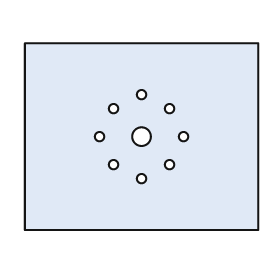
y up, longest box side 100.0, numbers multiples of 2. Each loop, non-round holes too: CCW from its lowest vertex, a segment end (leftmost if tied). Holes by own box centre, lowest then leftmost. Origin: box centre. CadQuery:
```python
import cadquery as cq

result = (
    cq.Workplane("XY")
    .moveTo(-50.0, -40.0)
    .lineTo(50.0, -40.0)
    .lineTo(50.0, 40.0)
    .lineTo(-50.0, 40.0)
    .close()
    .moveTo(0.0, -18.0)
    .circle(2.0)
    .moveTo(-12.0, -12.0)
    .circle(2.0)
    .moveTo(12.0, -12.0)
    .circle(2.0)
    .moveTo(-18.0, 0.0)
    .circle(2.0)
    .moveTo(0.0, 0.0)
    .circle(4.0)
    .moveTo(18.0, 0.0)
    .circle(2.0)
    .moveTo(-12.0, 12.0)
    .circle(2.0)
    .moveTo(12.0, 12.0)
    .circle(2.0)
    .moveTo(0.0, 18.0)
    .circle(2.0)
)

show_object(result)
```